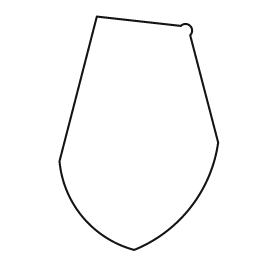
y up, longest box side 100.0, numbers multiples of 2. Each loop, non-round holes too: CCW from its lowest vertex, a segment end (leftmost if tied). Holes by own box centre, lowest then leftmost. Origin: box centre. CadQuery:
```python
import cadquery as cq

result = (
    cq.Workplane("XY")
    .moveTo(-2.0, -50.0)
    .threePointArc((22.0, -32.0), (34.0, -4.0))
    .lineTo(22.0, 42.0)
    .threePointArc((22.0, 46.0), (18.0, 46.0))
    .lineTo(-18.0, 50.0)
    .lineTo(-34.0, -12.0)
    .threePointArc((-24.0, -36.0), (-2.0, -50.0))
    .close()
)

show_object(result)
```